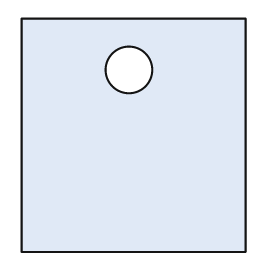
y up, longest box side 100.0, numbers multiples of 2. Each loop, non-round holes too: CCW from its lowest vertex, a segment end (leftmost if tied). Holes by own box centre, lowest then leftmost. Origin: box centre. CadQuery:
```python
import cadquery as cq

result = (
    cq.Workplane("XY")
    .moveTo(-48.0, -50.0)
    .lineTo(48.0, -50.0)
    .lineTo(48.0, 50.0)
    .lineTo(-48.0, 50.0)
    .close()
    .moveTo(-2.0, 28.0)
    .circle(10.0)
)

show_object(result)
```